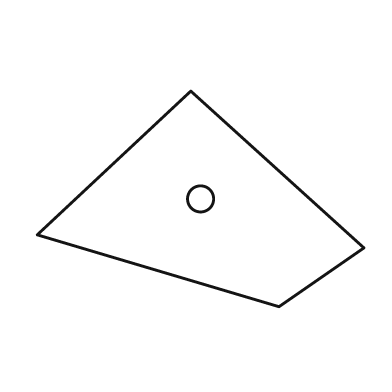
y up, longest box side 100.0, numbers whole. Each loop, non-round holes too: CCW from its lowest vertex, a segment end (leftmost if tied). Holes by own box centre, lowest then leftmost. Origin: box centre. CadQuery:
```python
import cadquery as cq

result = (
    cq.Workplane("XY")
    .moveTo(24.0, -33.0)
    .lineTo(50.0, -15.0)
    .lineTo(-3.0, 33.0)
    .lineTo(-50.0, -11.0)
    .close()
    .moveTo(0.0, 0.0)
    .circle(4.0)
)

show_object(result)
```